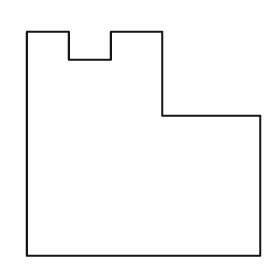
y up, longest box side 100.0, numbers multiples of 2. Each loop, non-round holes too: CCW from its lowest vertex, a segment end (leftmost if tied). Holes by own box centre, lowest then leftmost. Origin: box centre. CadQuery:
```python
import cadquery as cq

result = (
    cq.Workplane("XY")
    .moveTo(-50.0, -48.0)
    .lineTo(50.0, -48.0)
    .lineTo(50.0, 12.0)
    .lineTo(8.0, 12.0)
    .lineTo(8.0, 48.0)
    .lineTo(-14.0, 48.0)
    .lineTo(-14.0, 36.0)
    .lineTo(-32.0, 36.0)
    .lineTo(-32.0, 48.0)
    .lineTo(-50.0, 48.0)
    .close()
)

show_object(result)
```